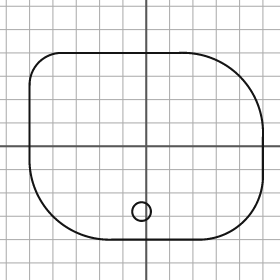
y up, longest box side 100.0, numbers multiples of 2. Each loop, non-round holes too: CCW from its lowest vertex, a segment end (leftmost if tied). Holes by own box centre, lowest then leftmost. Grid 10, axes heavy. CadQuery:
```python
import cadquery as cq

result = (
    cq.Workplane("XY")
    .moveTo(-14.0, -40.0)
    .lineTo(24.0, -40.0)
    .threePointArc((42.0, -32.0), (50.0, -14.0))
    .lineTo(50.0, 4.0)
    .threePointArc((40.0, 30.0), (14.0, 40.0))
    .lineTo(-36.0, 40.0)
    .threePointArc((-46.0, 36.0), (-50.0, 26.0))
    .lineTo(-50.0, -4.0)
    .threePointArc((-40.0, -30.0), (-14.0, -40.0))
    .close()
    .moveTo(-2.0, -28.0)
    .circle(4.0)
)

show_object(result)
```